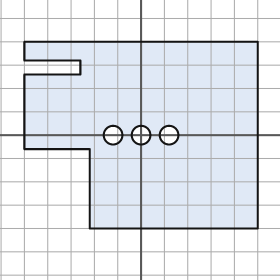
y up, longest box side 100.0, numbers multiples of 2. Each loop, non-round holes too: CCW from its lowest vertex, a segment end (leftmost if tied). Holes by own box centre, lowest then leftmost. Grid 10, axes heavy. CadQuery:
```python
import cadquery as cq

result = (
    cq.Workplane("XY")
    .moveTo(-22.0, -40.0)
    .lineTo(50.0, -40.0)
    .lineTo(50.0, 40.0)
    .lineTo(-50.0, 40.0)
    .lineTo(-50.0, 32.0)
    .lineTo(-26.0, 32.0)
    .lineTo(-26.0, 26.0)
    .lineTo(-50.0, 26.0)
    .lineTo(-50.0, -6.0)
    .lineTo(-22.0, -6.0)
    .close()
    .moveTo(-12.0, 0.0)
    .circle(4.0)
    .moveTo(0.0, 0.0)
    .circle(4.0)
    .moveTo(12.0, 0.0)
    .circle(4.0)
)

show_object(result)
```